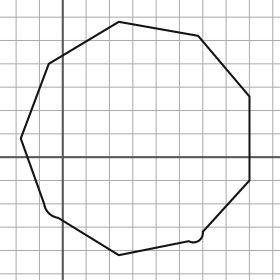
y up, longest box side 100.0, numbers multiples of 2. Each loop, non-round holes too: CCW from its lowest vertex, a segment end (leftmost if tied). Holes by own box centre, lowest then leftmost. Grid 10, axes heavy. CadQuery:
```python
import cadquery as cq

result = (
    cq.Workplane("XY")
    .moveTo(24.0, -42.0)
    .lineTo(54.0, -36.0)
    .threePointArc((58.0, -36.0), (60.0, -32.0))
    .lineTo(80.0, -10.0)
    .lineTo(80.0, 26.0)
    .lineTo(58.0, 52.0)
    .lineTo(24.0, 58.0)
    .lineTo(-6.0, 40.0)
    .lineTo(-18.0, 8.0)
    .lineTo(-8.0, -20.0)
    .threePointArc((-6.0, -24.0), (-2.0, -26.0))
    .close()
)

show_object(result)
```